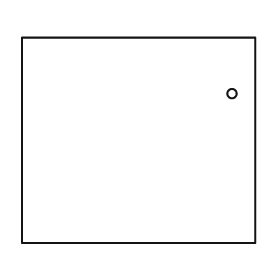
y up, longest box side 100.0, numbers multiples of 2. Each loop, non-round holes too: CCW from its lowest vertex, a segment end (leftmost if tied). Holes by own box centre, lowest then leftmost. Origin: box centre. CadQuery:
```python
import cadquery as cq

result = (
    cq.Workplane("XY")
    .moveTo(-50.0, -44.0)
    .lineTo(50.0, -44.0)
    .lineTo(50.0, 44.0)
    .lineTo(-50.0, 44.0)
    .close()
    .moveTo(40.0, 20.0)
    .circle(2.0)
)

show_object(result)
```